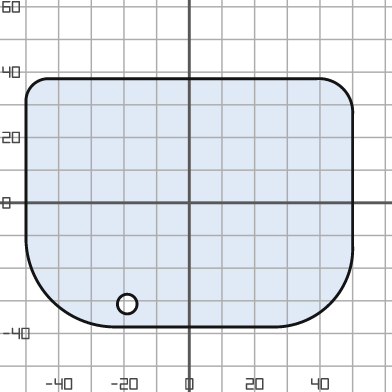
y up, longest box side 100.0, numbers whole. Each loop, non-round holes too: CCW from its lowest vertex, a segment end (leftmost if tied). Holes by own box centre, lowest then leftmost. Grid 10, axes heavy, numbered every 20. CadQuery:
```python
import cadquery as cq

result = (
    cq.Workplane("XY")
    .moveTo(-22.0, -38.0)
    .lineTo(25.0, -38.0)
    .threePointArc((43.0, -31.0), (50.0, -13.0))
    .lineTo(50.0, 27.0)
    .threePointArc((47.0, 35.0), (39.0, 38.0))
    .lineTo(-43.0, 38.0)
    .threePointArc((-48.0, 36.0), (-50.0, 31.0))
    .lineTo(-50.0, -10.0)
    .threePointArc((-42.0, -30.0), (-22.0, -38.0))
    .close()
    .moveTo(-19.0, -31.0)
    .circle(3.0)
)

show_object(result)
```